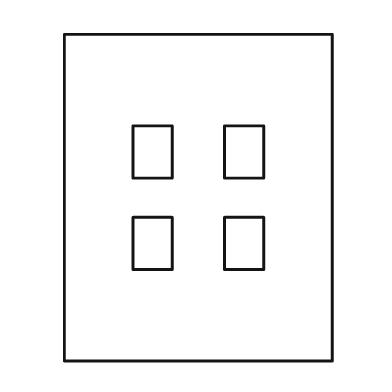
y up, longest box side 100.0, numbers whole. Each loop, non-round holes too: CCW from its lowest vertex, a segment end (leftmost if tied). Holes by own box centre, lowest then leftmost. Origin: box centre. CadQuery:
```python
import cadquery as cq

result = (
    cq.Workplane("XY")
    .moveTo(-41.0, -50.0)
    .lineTo(41.0, -50.0)
    .lineTo(41.0, 50.0)
    .lineTo(-41.0, 50.0)
    .close()
    .moveTo(-20.0, -22.0)
    .lineTo(-8.0, -22.0)
    .lineTo(-8.0, -6.0)
    .lineTo(-20.0, -6.0)
    .close()
    .moveTo(8.0, -22.0)
    .lineTo(20.0, -22.0)
    .lineTo(20.0, -6.0)
    .lineTo(8.0, -6.0)
    .close()
    .moveTo(-20.0, 6.0)
    .lineTo(-8.0, 6.0)
    .lineTo(-8.0, 22.0)
    .lineTo(-20.0, 22.0)
    .close()
    .moveTo(8.0, 6.0)
    .lineTo(20.0, 6.0)
    .lineTo(20.0, 22.0)
    .lineTo(8.0, 22.0)
    .close()
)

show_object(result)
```